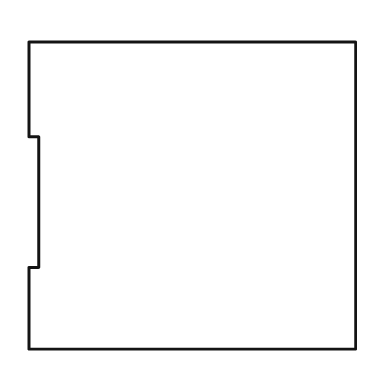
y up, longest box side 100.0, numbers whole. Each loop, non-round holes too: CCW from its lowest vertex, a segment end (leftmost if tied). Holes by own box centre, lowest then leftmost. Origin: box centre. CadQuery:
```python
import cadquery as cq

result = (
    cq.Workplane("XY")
    .moveTo(-50.0, -47.0)
    .lineTo(50.0, -47.0)
    .lineTo(50.0, 47.0)
    .lineTo(-50.0, 47.0)
    .lineTo(-50.0, 18.0)
    .lineTo(-47.0, 18.0)
    .lineTo(-47.0, -22.0)
    .lineTo(-50.0, -22.0)
    .close()
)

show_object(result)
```